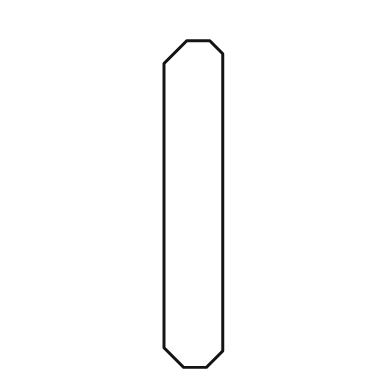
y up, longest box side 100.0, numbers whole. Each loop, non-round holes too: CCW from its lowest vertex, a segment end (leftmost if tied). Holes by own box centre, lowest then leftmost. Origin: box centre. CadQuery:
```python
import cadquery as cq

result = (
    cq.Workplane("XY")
    .moveTo(-3.0, -50.0)
    .lineTo(4.0, -50.0)
    .lineTo(9.0, -45.0)
    .lineTo(9.0, 46.0)
    .lineTo(5.0, 50.0)
    .lineTo(-2.0, 50.0)
    .lineTo(-9.0, 43.0)
    .lineTo(-9.0, -44.0)
    .close()
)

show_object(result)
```